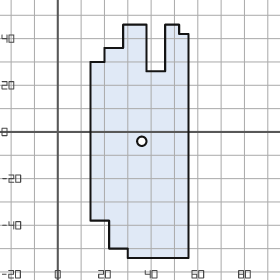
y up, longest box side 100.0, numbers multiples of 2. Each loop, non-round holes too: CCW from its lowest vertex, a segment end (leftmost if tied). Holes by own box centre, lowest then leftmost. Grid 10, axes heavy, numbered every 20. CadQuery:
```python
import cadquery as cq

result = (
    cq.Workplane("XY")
    .moveTo(30.0, -54.0)
    .lineTo(56.0, -54.0)
    .lineTo(56.0, 42.0)
    .lineTo(52.0, 42.0)
    .lineTo(52.0, 46.0)
    .lineTo(46.0, 46.0)
    .lineTo(46.0, 26.0)
    .lineTo(38.0, 26.0)
    .lineTo(38.0, 46.0)
    .lineTo(28.0, 46.0)
    .lineTo(28.0, 36.0)
    .lineTo(20.0, 36.0)
    .lineTo(20.0, 30.0)
    .lineTo(14.0, 30.0)
    .lineTo(14.0, -38.0)
    .lineTo(22.0, -38.0)
    .lineTo(22.0, -50.0)
    .lineTo(30.0, -50.0)
    .close()
    .moveTo(36.0, -4.0)
    .circle(2.0)
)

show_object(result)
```